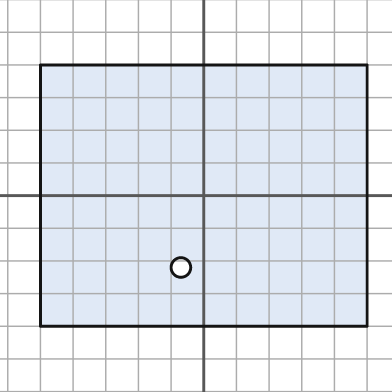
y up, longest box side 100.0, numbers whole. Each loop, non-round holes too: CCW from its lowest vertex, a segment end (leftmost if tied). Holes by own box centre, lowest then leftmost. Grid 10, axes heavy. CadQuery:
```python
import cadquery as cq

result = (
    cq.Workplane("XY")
    .moveTo(-50.0, -40.0)
    .lineTo(50.0, -40.0)
    .lineTo(50.0, 40.0)
    .lineTo(-50.0, 40.0)
    .close()
    .moveTo(-7.0, -22.0)
    .circle(3.0)
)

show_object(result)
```